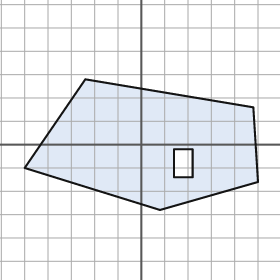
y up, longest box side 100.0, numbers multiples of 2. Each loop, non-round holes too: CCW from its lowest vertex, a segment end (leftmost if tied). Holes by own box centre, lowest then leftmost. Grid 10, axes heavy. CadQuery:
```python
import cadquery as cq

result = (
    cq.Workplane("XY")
    .moveTo(8.0, -28.0)
    .lineTo(50.0, -16.0)
    .lineTo(48.0, 16.0)
    .lineTo(-24.0, 28.0)
    .lineTo(-50.0, -10.0)
    .close()
    .moveTo(14.0, -14.0)
    .lineTo(22.0, -14.0)
    .lineTo(22.0, -2.0)
    .lineTo(14.0, -2.0)
    .close()
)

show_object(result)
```